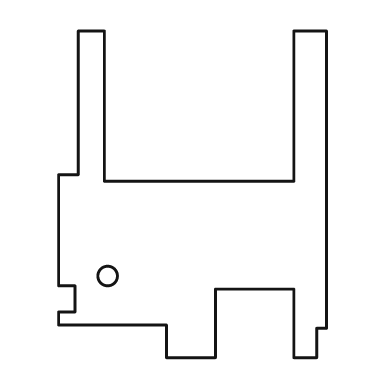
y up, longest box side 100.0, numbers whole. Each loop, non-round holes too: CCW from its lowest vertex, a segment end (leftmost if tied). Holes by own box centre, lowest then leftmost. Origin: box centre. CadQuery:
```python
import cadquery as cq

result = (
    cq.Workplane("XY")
    .moveTo(-8.0, -50.0)
    .lineTo(7.0, -50.0)
    .lineTo(7.0, -29.0)
    .lineTo(31.0, -29.0)
    .lineTo(31.0, -50.0)
    .lineTo(38.0, -50.0)
    .lineTo(38.0, -41.0)
    .lineTo(41.0, -41.0)
    .lineTo(41.0, 50.0)
    .lineTo(31.0, 50.0)
    .lineTo(31.0, 4.0)
    .lineTo(-27.0, 4.0)
    .lineTo(-27.0, 50.0)
    .lineTo(-35.0, 50.0)
    .lineTo(-35.0, 6.0)
    .lineTo(-41.0, 6.0)
    .lineTo(-41.0, -28.0)
    .lineTo(-36.0, -28.0)
    .lineTo(-36.0, -36.0)
    .lineTo(-41.0, -36.0)
    .lineTo(-41.0, -40.0)
    .lineTo(-8.0, -40.0)
    .close()
    .moveTo(-26.0, -25.0)
    .circle(3.0)
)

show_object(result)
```